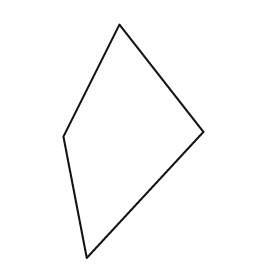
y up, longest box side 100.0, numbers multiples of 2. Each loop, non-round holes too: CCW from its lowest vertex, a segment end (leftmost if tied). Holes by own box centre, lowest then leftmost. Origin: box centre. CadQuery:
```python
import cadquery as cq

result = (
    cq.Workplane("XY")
    .moveTo(-20.0, -50.0)
    .lineTo(30.0, 4.0)
    .lineTo(-6.0, 50.0)
    .lineTo(-30.0, 2.0)
    .close()
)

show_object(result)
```